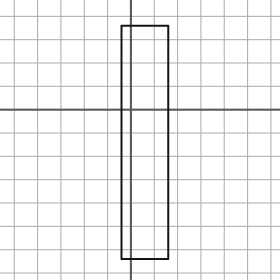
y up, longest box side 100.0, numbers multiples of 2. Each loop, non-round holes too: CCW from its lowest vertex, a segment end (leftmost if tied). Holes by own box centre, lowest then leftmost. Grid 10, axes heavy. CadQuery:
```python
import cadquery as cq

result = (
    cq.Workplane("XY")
    .moveTo(-4.0, -64.0)
    .lineTo(16.0, -64.0)
    .lineTo(16.0, 36.0)
    .lineTo(-4.0, 36.0)
    .close()
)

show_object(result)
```